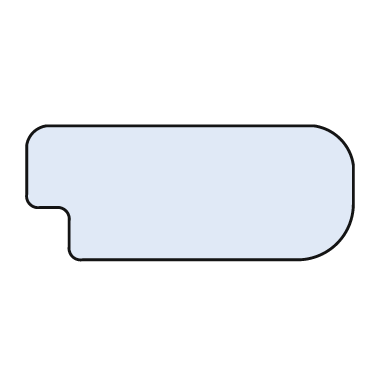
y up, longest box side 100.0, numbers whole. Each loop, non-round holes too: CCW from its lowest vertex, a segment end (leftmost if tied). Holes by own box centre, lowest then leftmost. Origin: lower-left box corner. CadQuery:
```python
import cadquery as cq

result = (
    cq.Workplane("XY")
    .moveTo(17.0, 0.0)
    .lineTo(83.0, 0.0)
    .threePointArc((95.0, 5.0), (100.0, 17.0))
    .lineTo(100.0, 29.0)
    .threePointArc((96.0, 37.0), (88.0, 41.0))
    .lineTo(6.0, 41.0)
    .threePointArc((2.0, 39.0), (0.0, 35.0))
    .lineTo(0.0, 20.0)
    .threePointArc((1.0, 17.0), (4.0, 16.0))
    .lineTo(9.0, 16.0)
    .threePointArc((12.0, 15.0), (13.0, 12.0))
    .lineTo(13.0, 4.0)
    .threePointArc((14.0, 1.0), (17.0, 0.0))
    .close()
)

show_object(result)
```